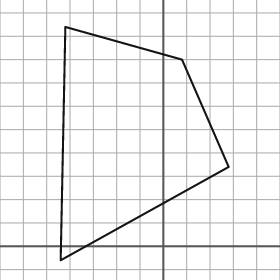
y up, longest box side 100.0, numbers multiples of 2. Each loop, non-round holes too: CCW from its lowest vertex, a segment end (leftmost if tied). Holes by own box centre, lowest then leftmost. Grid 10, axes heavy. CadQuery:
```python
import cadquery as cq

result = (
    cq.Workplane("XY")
    .moveTo(-44.0, -6.0)
    .lineTo(28.0, 34.0)
    .lineTo(8.0, 80.0)
    .lineTo(-42.0, 94.0)
    .close()
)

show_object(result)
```